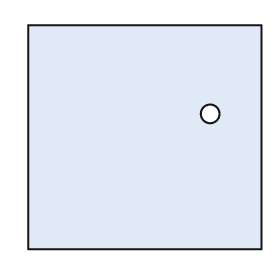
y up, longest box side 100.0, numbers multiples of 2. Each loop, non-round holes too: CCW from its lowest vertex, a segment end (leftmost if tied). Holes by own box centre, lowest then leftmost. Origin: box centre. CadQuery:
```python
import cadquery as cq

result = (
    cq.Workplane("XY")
    .moveTo(-50.0, -48.0)
    .lineTo(50.0, -48.0)
    .lineTo(50.0, 48.0)
    .lineTo(-50.0, 48.0)
    .close()
    .moveTo(28.0, 10.0)
    .circle(4.0)
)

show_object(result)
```